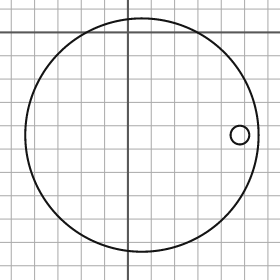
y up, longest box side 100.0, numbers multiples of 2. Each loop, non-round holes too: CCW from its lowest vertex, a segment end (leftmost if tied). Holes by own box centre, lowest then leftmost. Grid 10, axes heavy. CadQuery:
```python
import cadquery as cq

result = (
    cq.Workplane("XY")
    .moveTo(6.0, -44.0)
    .circle(50.0)
    .moveTo(48.0, -44.0)
    .circle(4.0)
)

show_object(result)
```